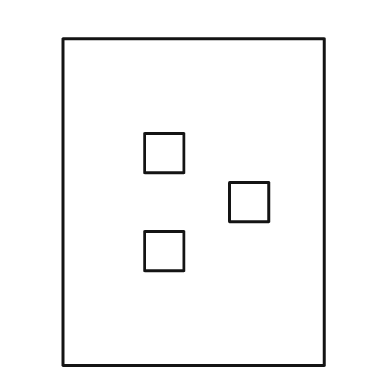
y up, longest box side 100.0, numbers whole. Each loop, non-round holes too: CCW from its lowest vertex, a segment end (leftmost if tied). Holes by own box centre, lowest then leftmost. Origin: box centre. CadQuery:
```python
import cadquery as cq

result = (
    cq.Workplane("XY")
    .moveTo(-40.0, -50.0)
    .lineTo(40.0, -50.0)
    .lineTo(40.0, 50.0)
    .lineTo(-40.0, 50.0)
    .close()
    .moveTo(-15.0, -21.0)
    .lineTo(-3.0, -21.0)
    .lineTo(-3.0, -9.0)
    .lineTo(-15.0, -9.0)
    .close()
    .moveTo(11.0, -6.0)
    .lineTo(23.0, -6.0)
    .lineTo(23.0, 6.0)
    .lineTo(11.0, 6.0)
    .close()
    .moveTo(-15.0, 9.0)
    .lineTo(-3.0, 9.0)
    .lineTo(-3.0, 21.0)
    .lineTo(-15.0, 21.0)
    .close()
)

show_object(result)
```